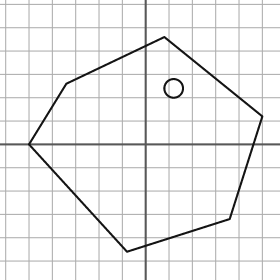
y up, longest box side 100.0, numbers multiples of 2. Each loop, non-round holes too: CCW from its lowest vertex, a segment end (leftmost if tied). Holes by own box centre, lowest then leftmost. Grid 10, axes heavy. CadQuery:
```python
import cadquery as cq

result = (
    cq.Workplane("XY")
    .moveTo(-8.0, -46.0)
    .lineTo(36.0, -32.0)
    .lineTo(50.0, 12.0)
    .lineTo(8.0, 46.0)
    .lineTo(-34.0, 26.0)
    .lineTo(-50.0, 0.0)
    .close()
    .moveTo(12.0, 24.0)
    .circle(4.0)
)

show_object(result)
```